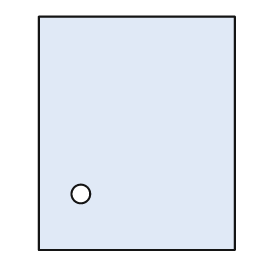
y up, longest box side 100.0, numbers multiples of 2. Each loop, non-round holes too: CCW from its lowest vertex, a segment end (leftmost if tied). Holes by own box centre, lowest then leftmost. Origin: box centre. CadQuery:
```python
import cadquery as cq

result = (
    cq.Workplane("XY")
    .moveTo(-42.0, -50.0)
    .lineTo(42.0, -50.0)
    .lineTo(42.0, 50.0)
    .lineTo(-42.0, 50.0)
    .close()
    .moveTo(-24.0, -26.0)
    .circle(4.0)
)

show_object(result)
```